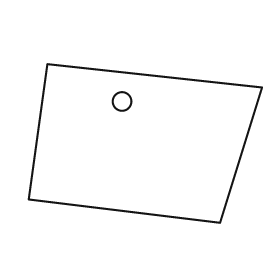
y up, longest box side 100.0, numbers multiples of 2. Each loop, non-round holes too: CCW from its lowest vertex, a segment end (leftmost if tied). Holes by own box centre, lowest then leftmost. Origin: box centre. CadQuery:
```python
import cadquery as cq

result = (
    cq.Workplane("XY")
    .moveTo(32.0, -34.0)
    .lineTo(50.0, 24.0)
    .lineTo(-42.0, 34.0)
    .lineTo(-50.0, -24.0)
    .close()
    .moveTo(-10.0, 18.0)
    .circle(4.0)
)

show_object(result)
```